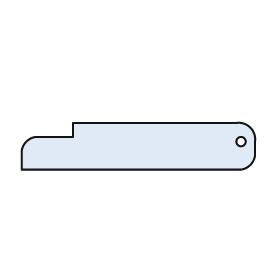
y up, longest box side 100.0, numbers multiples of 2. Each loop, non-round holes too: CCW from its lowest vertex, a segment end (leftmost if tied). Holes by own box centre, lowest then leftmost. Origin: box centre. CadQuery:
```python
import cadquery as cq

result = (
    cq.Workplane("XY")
    .moveTo(-50.0, -10.0)
    .lineTo(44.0, -10.0)
    .threePointArc((48.0, -8.0), (50.0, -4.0))
    .lineTo(50.0, 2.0)
    .threePointArc((48.0, 8.0), (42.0, 10.0))
    .lineTo(-28.0, 10.0)
    .lineTo(-28.0, 4.0)
    .lineTo(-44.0, 4.0)
    .threePointArc((-48.0, 2.0), (-50.0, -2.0))
    .close()
    .moveTo(44.0, 2.0)
    .circle(2.0)
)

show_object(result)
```